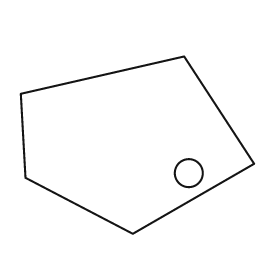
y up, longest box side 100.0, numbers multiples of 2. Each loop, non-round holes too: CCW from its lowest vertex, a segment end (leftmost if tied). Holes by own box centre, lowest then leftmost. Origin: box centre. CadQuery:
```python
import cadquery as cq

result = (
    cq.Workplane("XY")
    .moveTo(-2.0, -38.0)
    .lineTo(50.0, -8.0)
    .lineTo(20.0, 38.0)
    .lineTo(-50.0, 22.0)
    .lineTo(-48.0, -14.0)
    .close()
    .moveTo(22.0, -12.0)
    .circle(6.0)
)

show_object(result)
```